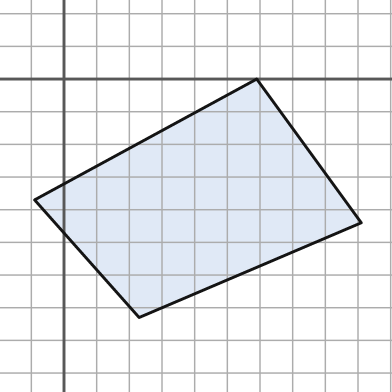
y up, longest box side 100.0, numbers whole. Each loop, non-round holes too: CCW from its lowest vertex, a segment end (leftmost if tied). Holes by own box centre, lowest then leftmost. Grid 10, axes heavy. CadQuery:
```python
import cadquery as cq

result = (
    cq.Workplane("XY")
    .moveTo(23.0, -73.0)
    .lineTo(91.0, -44.0)
    .lineTo(59.0, 0.0)
    .lineTo(-9.0, -37.0)
    .close()
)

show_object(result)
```